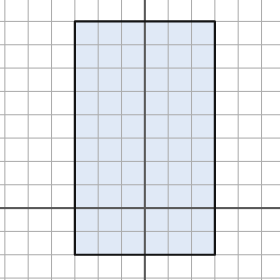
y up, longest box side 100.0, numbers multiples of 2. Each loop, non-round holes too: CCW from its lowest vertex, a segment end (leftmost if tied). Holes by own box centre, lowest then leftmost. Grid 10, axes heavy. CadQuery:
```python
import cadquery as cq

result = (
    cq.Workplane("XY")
    .moveTo(-30.0, -20.0)
    .lineTo(30.0, -20.0)
    .lineTo(30.0, 80.0)
    .lineTo(-30.0, 80.0)
    .close()
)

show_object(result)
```